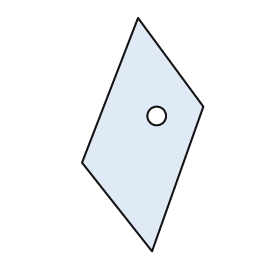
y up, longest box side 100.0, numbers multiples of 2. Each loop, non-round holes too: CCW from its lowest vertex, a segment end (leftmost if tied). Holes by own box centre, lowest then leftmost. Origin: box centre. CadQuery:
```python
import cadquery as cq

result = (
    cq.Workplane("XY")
    .moveTo(4.0, -50.0)
    .lineTo(26.0, 12.0)
    .lineTo(-2.0, 50.0)
    .lineTo(-26.0, -12.0)
    .close()
    .moveTo(6.0, 8.0)
    .circle(4.0)
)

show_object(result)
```